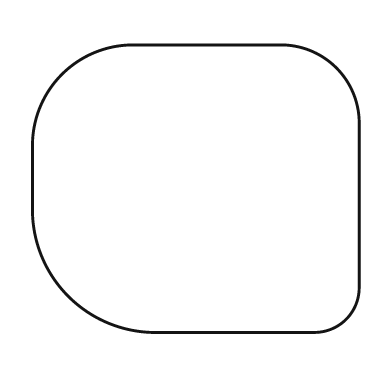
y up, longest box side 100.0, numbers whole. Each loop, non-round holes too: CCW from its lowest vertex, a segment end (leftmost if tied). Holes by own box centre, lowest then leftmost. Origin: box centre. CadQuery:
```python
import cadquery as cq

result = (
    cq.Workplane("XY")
    .moveTo(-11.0, -44.0)
    .lineTo(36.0, -44.0)
    .threePointArc((46.0, -40.0), (50.0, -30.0))
    .lineTo(50.0, 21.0)
    .threePointArc((43.0, 37.0), (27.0, 44.0))
    .lineTo(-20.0, 44.0)
    .threePointArc((-41.0, 35.0), (-50.0, 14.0))
    .lineTo(-50.0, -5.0)
    .threePointArc((-39.0, -33.0), (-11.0, -44.0))
    .close()
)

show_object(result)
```